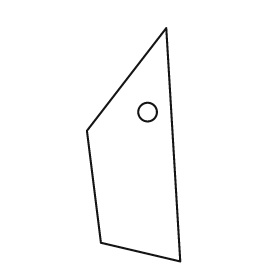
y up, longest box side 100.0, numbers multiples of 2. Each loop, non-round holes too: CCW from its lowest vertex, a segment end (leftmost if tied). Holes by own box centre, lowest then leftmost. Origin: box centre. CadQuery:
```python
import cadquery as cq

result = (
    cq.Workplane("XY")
    .moveTo(20.0, -50.0)
    .lineTo(14.0, 50.0)
    .lineTo(-20.0, 6.0)
    .lineTo(-14.0, -42.0)
    .close()
    .moveTo(6.0, 14.0)
    .circle(4.0)
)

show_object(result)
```